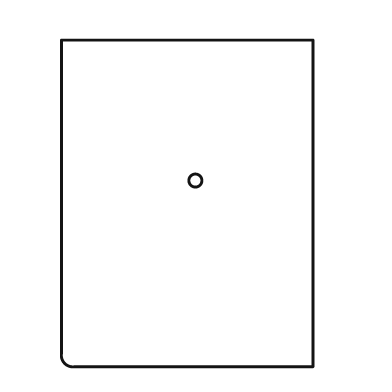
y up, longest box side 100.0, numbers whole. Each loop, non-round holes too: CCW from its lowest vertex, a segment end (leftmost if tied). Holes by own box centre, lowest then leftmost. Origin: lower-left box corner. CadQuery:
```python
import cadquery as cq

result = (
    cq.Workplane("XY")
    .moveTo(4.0, 0.0)
    .lineTo(77.0, 0.0)
    .lineTo(77.0, 100.0)
    .lineTo(0.0, 100.0)
    .lineTo(0.0, 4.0)
    .threePointArc((1.0, 1.0), (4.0, 0.0))
    .close()
    .moveTo(41.0, 57.0)
    .circle(2.0)
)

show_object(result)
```